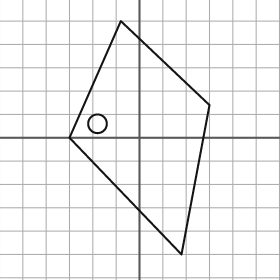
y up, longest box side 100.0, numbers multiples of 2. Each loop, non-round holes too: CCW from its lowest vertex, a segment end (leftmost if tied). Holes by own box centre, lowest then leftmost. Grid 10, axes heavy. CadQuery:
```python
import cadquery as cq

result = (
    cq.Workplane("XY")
    .moveTo(18.0, -50.0)
    .lineTo(30.0, 14.0)
    .lineTo(-8.0, 50.0)
    .lineTo(-30.0, 0.0)
    .close()
    .moveTo(-18.0, 6.0)
    .circle(4.0)
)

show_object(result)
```